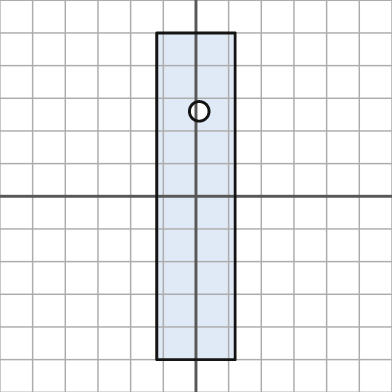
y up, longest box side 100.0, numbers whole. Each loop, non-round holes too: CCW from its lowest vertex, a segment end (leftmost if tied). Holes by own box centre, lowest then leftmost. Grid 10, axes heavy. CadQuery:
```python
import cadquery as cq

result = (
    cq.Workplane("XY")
    .moveTo(-12.0, -50.0)
    .lineTo(12.0, -50.0)
    .lineTo(12.0, 50.0)
    .lineTo(-12.0, 50.0)
    .close()
    .moveTo(1.0, 26.0)
    .circle(3.0)
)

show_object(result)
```